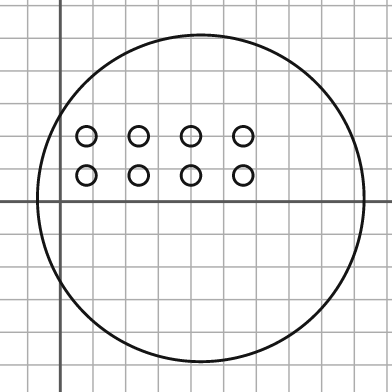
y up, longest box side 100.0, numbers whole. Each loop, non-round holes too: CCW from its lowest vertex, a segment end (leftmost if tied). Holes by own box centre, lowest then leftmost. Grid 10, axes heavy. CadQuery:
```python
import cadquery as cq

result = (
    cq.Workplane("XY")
    .moveTo(43.0, 1.0)
    .circle(50.0)
    .moveTo(8.0, 8.0)
    .circle(3.0)
    .moveTo(24.0, 8.0)
    .circle(3.0)
    .moveTo(40.0, 8.0)
    .circle(3.0)
    .moveTo(56.0, 8.0)
    .circle(3.0)
    .moveTo(8.0, 20.0)
    .circle(3.0)
    .moveTo(24.0, 20.0)
    .circle(3.0)
    .moveTo(40.0, 20.0)
    .circle(3.0)
    .moveTo(56.0, 20.0)
    .circle(3.0)
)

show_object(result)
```